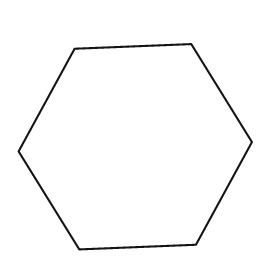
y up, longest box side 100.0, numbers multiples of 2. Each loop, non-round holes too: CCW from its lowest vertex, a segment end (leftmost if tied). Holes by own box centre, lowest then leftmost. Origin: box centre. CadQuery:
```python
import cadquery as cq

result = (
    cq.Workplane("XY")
    .moveTo(-24.0, -44.0)
    .lineTo(26.0, -42.0)
    .lineTo(50.0, 2.0)
    .lineTo(24.0, 44.0)
    .lineTo(-26.0, 42.0)
    .lineTo(-50.0, -2.0)
    .close()
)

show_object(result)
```